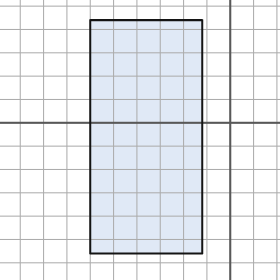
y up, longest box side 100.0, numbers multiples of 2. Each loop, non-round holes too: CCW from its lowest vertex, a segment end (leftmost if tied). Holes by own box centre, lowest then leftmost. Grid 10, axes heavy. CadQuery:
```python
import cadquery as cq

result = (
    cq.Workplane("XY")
    .moveTo(-60.0, -56.0)
    .lineTo(-12.0, -56.0)
    .lineTo(-12.0, 44.0)
    .lineTo(-60.0, 44.0)
    .close()
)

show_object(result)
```